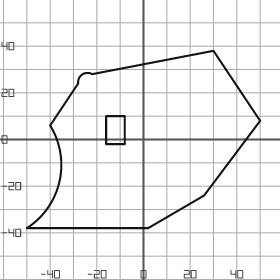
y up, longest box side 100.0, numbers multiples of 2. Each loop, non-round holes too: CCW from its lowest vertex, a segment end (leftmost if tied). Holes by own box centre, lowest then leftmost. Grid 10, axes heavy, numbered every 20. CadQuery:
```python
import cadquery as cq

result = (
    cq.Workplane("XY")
    .moveTo(-50.0, -38.0)
    .lineTo(2.0, -38.0)
    .lineTo(26.0, -24.0)
    .lineTo(50.0, 8.0)
    .lineTo(30.0, 38.0)
    .lineTo(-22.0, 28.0)
    .threePointArc((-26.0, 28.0), (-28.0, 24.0))
    .lineTo(-40.0, 6.0)
    .threePointArc((-36.0, -18.0), (-50.0, -38.0))
    .close()
    .moveTo(-16.0, -2.0)
    .lineTo(-8.0, -2.0)
    .lineTo(-8.0, 10.0)
    .lineTo(-16.0, 10.0)
    .close()
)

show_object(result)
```